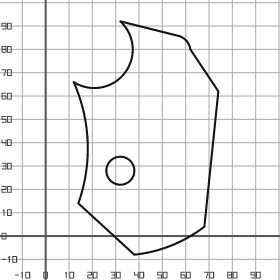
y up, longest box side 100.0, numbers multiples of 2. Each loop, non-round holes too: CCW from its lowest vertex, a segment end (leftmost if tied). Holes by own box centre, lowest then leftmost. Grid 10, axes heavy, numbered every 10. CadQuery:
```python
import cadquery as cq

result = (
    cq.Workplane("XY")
    .moveTo(38.0, -8.0)
    .threePointArc((54.0, -4.0), (68.0, 4.0))
    .lineTo(74.0, 62.0)
    .lineTo(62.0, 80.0)
    .threePointArc((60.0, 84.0), (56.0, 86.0))
    .lineTo(32.0, 92.0)
    .threePointArc((34.0, 70.0), (12.0, 66.0))
    .threePointArc((18.0, 40.0), (14.0, 14.0))
    .close()
    .moveTo(32.0, 28.0)
    .circle(6.0)
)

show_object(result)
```